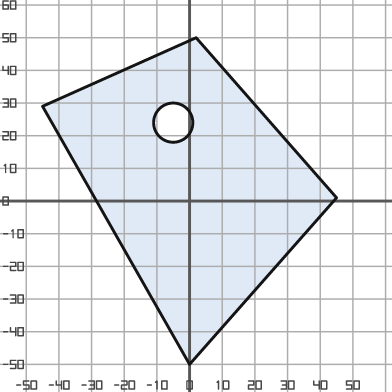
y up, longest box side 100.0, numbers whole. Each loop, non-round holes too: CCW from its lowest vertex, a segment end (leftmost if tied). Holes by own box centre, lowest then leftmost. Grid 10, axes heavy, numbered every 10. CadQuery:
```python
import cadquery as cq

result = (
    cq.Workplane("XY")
    .moveTo(0.0, -50.0)
    .lineTo(45.0, 1.0)
    .lineTo(2.0, 50.0)
    .lineTo(-45.0, 29.0)
    .close()
    .moveTo(-5.0, 24.0)
    .circle(6.0)
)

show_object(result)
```